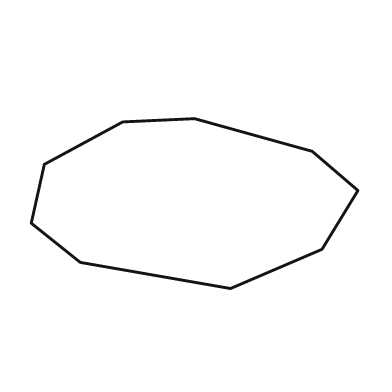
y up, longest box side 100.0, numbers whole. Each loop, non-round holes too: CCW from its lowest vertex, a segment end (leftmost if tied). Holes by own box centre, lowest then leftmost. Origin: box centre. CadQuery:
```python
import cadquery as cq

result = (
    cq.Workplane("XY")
    .moveTo(11.0, -26.0)
    .lineTo(39.0, -14.0)
    .lineTo(50.0, 4.0)
    .lineTo(36.0, 16.0)
    .lineTo(0.0, 26.0)
    .lineTo(-22.0, 25.0)
    .lineTo(-46.0, 12.0)
    .lineTo(-50.0, -6.0)
    .lineTo(-35.0, -18.0)
    .close()
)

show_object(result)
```